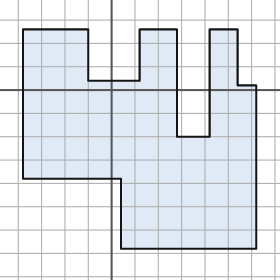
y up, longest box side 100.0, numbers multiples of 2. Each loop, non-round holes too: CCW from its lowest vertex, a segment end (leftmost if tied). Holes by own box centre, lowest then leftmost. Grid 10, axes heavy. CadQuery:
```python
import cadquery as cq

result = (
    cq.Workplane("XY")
    .moveTo(4.0, -68.0)
    .lineTo(62.0, -68.0)
    .lineTo(62.0, 2.0)
    .lineTo(54.0, 2.0)
    .lineTo(54.0, 26.0)
    .lineTo(42.0, 26.0)
    .lineTo(42.0, -20.0)
    .lineTo(28.0, -20.0)
    .lineTo(28.0, 26.0)
    .lineTo(12.0, 26.0)
    .lineTo(12.0, 4.0)
    .lineTo(-10.0, 4.0)
    .lineTo(-10.0, 26.0)
    .lineTo(-38.0, 26.0)
    .lineTo(-38.0, -38.0)
    .lineTo(4.0, -38.0)
    .close()
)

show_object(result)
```